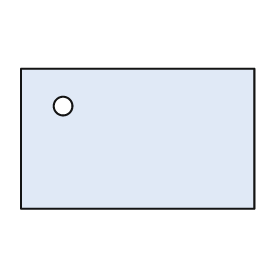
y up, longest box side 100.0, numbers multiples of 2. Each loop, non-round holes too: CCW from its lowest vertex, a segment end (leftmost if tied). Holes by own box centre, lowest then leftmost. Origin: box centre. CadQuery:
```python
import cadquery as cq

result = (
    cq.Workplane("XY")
    .moveTo(-50.0, -30.0)
    .lineTo(50.0, -30.0)
    .lineTo(50.0, 30.0)
    .lineTo(-50.0, 30.0)
    .close()
    .moveTo(-32.0, 14.0)
    .circle(4.0)
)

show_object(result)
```